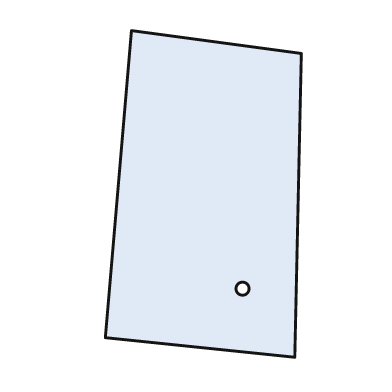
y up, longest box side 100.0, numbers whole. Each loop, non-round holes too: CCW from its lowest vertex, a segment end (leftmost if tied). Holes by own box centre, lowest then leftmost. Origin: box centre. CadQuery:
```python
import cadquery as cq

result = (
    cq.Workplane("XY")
    .moveTo(28.0, -50.0)
    .lineTo(30.0, 43.0)
    .lineTo(-22.0, 50.0)
    .lineTo(-30.0, -44.0)
    .close()
    .moveTo(12.0, -29.0)
    .circle(2.0)
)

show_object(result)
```